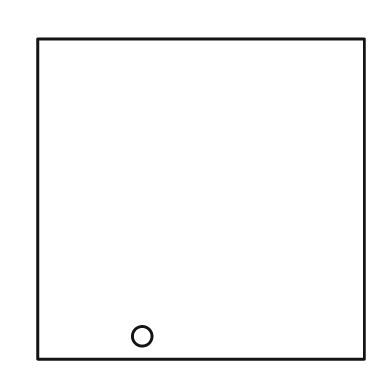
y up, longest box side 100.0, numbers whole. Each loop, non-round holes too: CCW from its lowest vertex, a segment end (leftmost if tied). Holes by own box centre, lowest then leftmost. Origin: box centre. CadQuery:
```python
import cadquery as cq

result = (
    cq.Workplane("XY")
    .moveTo(-50.0, -49.0)
    .lineTo(50.0, -49.0)
    .lineTo(50.0, 49.0)
    .lineTo(-50.0, 49.0)
    .close()
    .moveTo(-18.0, -42.0)
    .circle(3.0)
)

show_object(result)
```